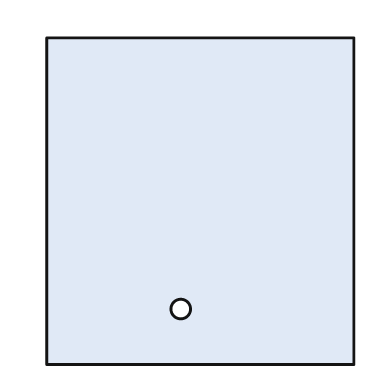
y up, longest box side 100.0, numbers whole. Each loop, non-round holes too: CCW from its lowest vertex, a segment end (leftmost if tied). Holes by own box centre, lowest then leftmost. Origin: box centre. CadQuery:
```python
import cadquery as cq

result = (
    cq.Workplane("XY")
    .moveTo(-47.0, -50.0)
    .lineTo(47.0, -50.0)
    .lineTo(47.0, 50.0)
    .lineTo(-47.0, 50.0)
    .close()
    .moveTo(-6.0, -33.0)
    .circle(3.0)
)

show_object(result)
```